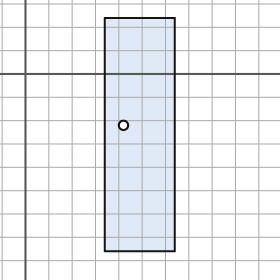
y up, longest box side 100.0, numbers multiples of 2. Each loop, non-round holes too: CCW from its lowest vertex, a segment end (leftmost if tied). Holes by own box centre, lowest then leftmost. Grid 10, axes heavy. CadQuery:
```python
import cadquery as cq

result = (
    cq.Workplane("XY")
    .moveTo(34.0, -76.0)
    .lineTo(64.0, -76.0)
    .lineTo(64.0, 24.0)
    .lineTo(34.0, 24.0)
    .close()
    .moveTo(42.0, -22.0)
    .circle(2.0)
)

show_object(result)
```